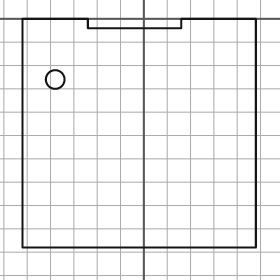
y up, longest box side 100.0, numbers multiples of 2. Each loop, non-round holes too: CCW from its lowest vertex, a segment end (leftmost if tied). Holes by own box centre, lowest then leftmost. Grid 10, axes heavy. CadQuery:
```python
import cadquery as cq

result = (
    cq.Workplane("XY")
    .moveTo(-52.0, -98.0)
    .lineTo(48.0, -98.0)
    .lineTo(48.0, 0.0)
    .lineTo(16.0, 0.0)
    .lineTo(16.0, -4.0)
    .lineTo(-24.0, -4.0)
    .lineTo(-24.0, 0.0)
    .lineTo(-52.0, 0.0)
    .close()
    .moveTo(-38.0, -26.0)
    .circle(4.0)
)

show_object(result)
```